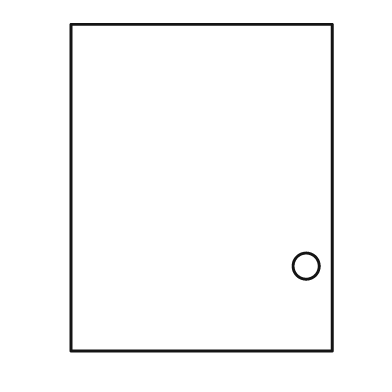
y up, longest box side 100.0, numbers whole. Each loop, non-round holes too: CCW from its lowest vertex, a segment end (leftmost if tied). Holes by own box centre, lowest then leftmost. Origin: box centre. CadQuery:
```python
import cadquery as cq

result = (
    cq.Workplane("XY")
    .moveTo(-40.0, -50.0)
    .lineTo(40.0, -50.0)
    .lineTo(40.0, 50.0)
    .lineTo(-40.0, 50.0)
    .close()
    .moveTo(32.0, -24.0)
    .circle(4.0)
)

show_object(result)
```